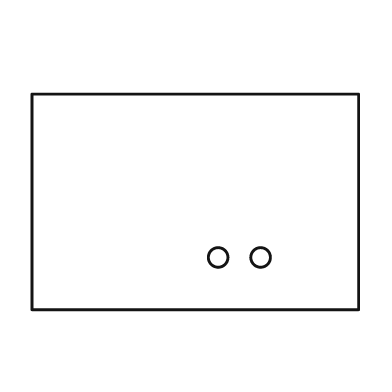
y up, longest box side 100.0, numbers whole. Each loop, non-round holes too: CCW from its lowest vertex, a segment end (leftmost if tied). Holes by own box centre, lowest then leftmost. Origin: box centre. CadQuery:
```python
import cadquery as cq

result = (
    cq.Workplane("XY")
    .moveTo(-50.0, -33.0)
    .lineTo(50.0, -33.0)
    .lineTo(50.0, 33.0)
    .lineTo(-50.0, 33.0)
    .close()
    .moveTo(7.0, -17.0)
    .circle(3.0)
    .moveTo(20.0, -17.0)
    .circle(3.0)
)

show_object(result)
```